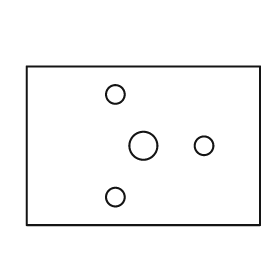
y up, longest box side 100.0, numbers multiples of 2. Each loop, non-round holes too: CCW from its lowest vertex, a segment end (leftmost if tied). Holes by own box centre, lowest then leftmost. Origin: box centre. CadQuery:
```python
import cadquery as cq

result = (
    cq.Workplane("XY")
    .moveTo(-50.0, -34.0)
    .lineTo(50.0, -34.0)
    .lineTo(50.0, 34.0)
    .lineTo(-50.0, 34.0)
    .close()
    .moveTo(-12.0, -22.0)
    .circle(4.0)
    .moveTo(0.0, 0.0)
    .circle(6.0)
    .moveTo(26.0, 0.0)
    .circle(4.0)
    .moveTo(-12.0, 22.0)
    .circle(4.0)
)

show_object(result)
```